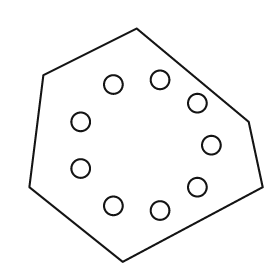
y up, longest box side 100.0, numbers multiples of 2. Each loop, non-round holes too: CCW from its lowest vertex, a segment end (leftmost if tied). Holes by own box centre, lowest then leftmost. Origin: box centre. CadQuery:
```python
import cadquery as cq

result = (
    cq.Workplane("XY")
    .moveTo(-10.0, -50.0)
    .lineTo(50.0, -18.0)
    .lineTo(44.0, 10.0)
    .lineTo(-4.0, 50.0)
    .lineTo(-44.0, 30.0)
    .lineTo(-50.0, -18.0)
    .close()
    .moveTo(6.0, -28.0)
    .circle(4.0)
    .moveTo(-14.0, -26.0)
    .circle(4.0)
    .moveTo(22.0, -18.0)
    .circle(4.0)
    .moveTo(-28.0, -10.0)
    .circle(4.0)
    .moveTo(28.0, 0.0)
    .circle(4.0)
    .moveTo(-28.0, 10.0)
    .circle(4.0)
    .moveTo(22.0, 18.0)
    .circle(4.0)
    .moveTo(-14.0, 26.0)
    .circle(4.0)
    .moveTo(6.0, 28.0)
    .circle(4.0)
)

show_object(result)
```